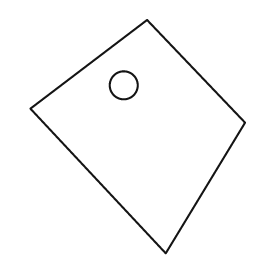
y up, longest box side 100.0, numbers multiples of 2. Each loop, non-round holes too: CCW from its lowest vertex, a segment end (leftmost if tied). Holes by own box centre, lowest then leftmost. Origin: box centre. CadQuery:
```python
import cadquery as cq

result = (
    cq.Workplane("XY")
    .moveTo(12.0, -50.0)
    .lineTo(46.0, 6.0)
    .lineTo(4.0, 50.0)
    .lineTo(-46.0, 12.0)
    .close()
    .moveTo(-6.0, 22.0)
    .circle(6.0)
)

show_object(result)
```